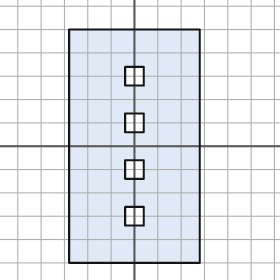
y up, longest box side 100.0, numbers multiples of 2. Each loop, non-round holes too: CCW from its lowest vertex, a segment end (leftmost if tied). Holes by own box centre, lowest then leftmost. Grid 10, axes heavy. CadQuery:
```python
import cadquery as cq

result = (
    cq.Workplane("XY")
    .moveTo(-28.0, -50.0)
    .lineTo(28.0, -50.0)
    .lineTo(28.0, 50.0)
    .lineTo(-28.0, 50.0)
    .close()
    .moveTo(-4.0, -34.0)
    .lineTo(4.0, -34.0)
    .lineTo(4.0, -26.0)
    .lineTo(-4.0, -26.0)
    .close()
    .moveTo(-4.0, -14.0)
    .lineTo(4.0, -14.0)
    .lineTo(4.0, -6.0)
    .lineTo(-4.0, -6.0)
    .close()
    .moveTo(-4.0, 6.0)
    .lineTo(4.0, 6.0)
    .lineTo(4.0, 14.0)
    .lineTo(-4.0, 14.0)
    .close()
    .moveTo(-4.0, 26.0)
    .lineTo(4.0, 26.0)
    .lineTo(4.0, 34.0)
    .lineTo(-4.0, 34.0)
    .close()
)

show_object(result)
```